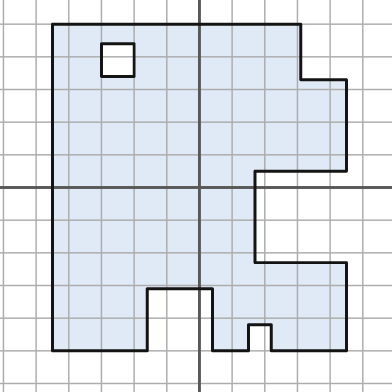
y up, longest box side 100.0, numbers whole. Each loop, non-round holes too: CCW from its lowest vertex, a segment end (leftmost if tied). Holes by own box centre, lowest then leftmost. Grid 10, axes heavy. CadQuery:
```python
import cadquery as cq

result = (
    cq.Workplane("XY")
    .moveTo(-45.0, -50.0)
    .lineTo(-16.0, -50.0)
    .lineTo(-16.0, -31.0)
    .lineTo(4.0, -31.0)
    .lineTo(4.0, -50.0)
    .lineTo(15.0, -50.0)
    .lineTo(15.0, -42.0)
    .lineTo(22.0, -42.0)
    .lineTo(22.0, -50.0)
    .lineTo(45.0, -50.0)
    .lineTo(45.0, -23.0)
    .lineTo(17.0, -23.0)
    .lineTo(17.0, 5.0)
    .lineTo(45.0, 5.0)
    .lineTo(45.0, 33.0)
    .lineTo(31.0, 33.0)
    .lineTo(31.0, 50.0)
    .lineTo(-45.0, 50.0)
    .close()
    .moveTo(-30.0, 34.0)
    .lineTo(-20.0, 34.0)
    .lineTo(-20.0, 44.0)
    .lineTo(-30.0, 44.0)
    .close()
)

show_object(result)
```